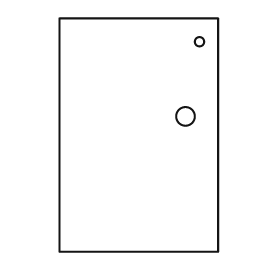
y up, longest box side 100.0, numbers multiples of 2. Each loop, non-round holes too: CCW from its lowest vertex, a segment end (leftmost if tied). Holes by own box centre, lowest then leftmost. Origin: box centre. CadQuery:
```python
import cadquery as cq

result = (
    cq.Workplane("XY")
    .moveTo(-34.0, -50.0)
    .lineTo(34.0, -50.0)
    .lineTo(34.0, 50.0)
    .lineTo(-34.0, 50.0)
    .close()
    .moveTo(20.0, 8.0)
    .circle(4.0)
    .moveTo(26.0, 40.0)
    .circle(2.0)
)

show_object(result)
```